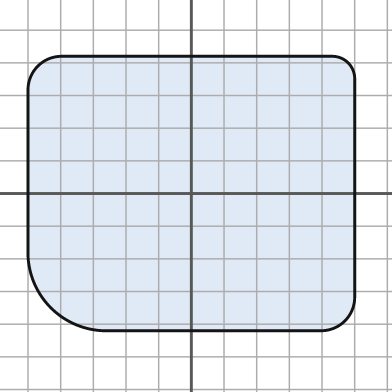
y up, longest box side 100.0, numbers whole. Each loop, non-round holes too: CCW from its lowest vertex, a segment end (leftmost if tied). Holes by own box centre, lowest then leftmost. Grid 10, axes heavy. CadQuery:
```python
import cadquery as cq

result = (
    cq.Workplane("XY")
    .moveTo(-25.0, -42.0)
    .lineTo(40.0, -42.0)
    .threePointArc((47.0, -39.0), (50.0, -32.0))
    .lineTo(50.0, 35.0)
    .threePointArc((48.0, 40.0), (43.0, 42.0))
    .lineTo(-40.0, 42.0)
    .threePointArc((-47.0, 39.0), (-50.0, 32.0))
    .lineTo(-50.0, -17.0)
    .threePointArc((-43.0, -35.0), (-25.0, -42.0))
    .close()
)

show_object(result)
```